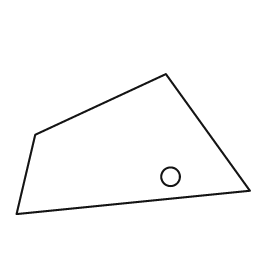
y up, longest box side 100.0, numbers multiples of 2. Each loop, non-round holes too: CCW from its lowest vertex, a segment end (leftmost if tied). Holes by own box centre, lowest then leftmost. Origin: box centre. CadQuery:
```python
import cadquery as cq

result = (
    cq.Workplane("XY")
    .moveTo(-50.0, -30.0)
    .lineTo(50.0, -20.0)
    .lineTo(14.0, 30.0)
    .lineTo(-42.0, 4.0)
    .close()
    .moveTo(16.0, -14.0)
    .circle(4.0)
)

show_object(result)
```